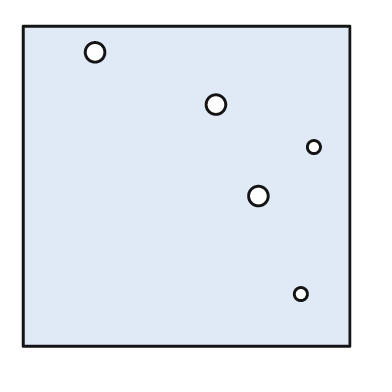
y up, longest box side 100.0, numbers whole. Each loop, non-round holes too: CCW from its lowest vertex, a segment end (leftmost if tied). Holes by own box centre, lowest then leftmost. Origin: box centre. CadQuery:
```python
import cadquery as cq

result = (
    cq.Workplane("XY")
    .moveTo(-50.0, -49.0)
    .lineTo(50.0, -49.0)
    .lineTo(50.0, 49.0)
    .lineTo(-50.0, 49.0)
    .close()
    .moveTo(35.0, -33.0)
    .circle(2.0)
    .moveTo(22.0, -3.0)
    .circle(3.0)
    .moveTo(39.0, 12.0)
    .circle(2.0)
    .moveTo(9.0, 25.0)
    .circle(3.0)
    .moveTo(-28.0, 41.0)
    .circle(3.0)
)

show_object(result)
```